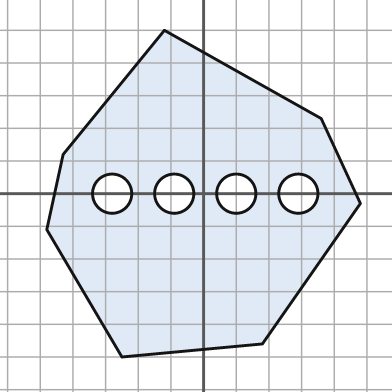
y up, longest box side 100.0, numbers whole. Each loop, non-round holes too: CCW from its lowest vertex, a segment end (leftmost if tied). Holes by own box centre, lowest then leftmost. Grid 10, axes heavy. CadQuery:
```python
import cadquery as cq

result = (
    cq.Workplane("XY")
    .moveTo(-25.0, -50.0)
    .lineTo(18.0, -46.0)
    .lineTo(48.0, -3.0)
    .lineTo(36.0, 23.0)
    .lineTo(-12.0, 50.0)
    .lineTo(-43.0, 12.0)
    .lineTo(-48.0, -11.0)
    .close()
    .moveTo(-28.0, 0.0)
    .circle(6.0)
    .moveTo(-9.0, 0.0)
    .circle(6.0)
    .moveTo(10.0, 0.0)
    .circle(6.0)
    .moveTo(29.0, 0.0)
    .circle(6.0)
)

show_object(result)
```